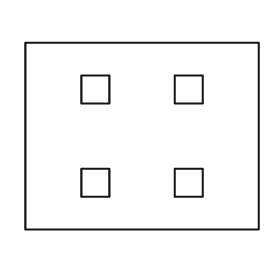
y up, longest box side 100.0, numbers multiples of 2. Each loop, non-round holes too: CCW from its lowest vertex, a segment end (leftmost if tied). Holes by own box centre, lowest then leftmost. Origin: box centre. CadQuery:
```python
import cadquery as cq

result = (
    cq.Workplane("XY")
    .moveTo(-50.0, -40.0)
    .lineTo(50.0, -40.0)
    .lineTo(50.0, 40.0)
    .lineTo(-50.0, 40.0)
    .close()
    .moveTo(-26.0, -26.0)
    .lineTo(-14.0, -26.0)
    .lineTo(-14.0, -14.0)
    .lineTo(-26.0, -14.0)
    .close()
    .moveTo(14.0, -26.0)
    .lineTo(26.0, -26.0)
    .lineTo(26.0, -14.0)
    .lineTo(14.0, -14.0)
    .close()
    .moveTo(-26.0, 14.0)
    .lineTo(-14.0, 14.0)
    .lineTo(-14.0, 26.0)
    .lineTo(-26.0, 26.0)
    .close()
    .moveTo(14.0, 14.0)
    .lineTo(26.0, 14.0)
    .lineTo(26.0, 26.0)
    .lineTo(14.0, 26.0)
    .close()
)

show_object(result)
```